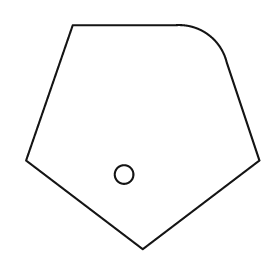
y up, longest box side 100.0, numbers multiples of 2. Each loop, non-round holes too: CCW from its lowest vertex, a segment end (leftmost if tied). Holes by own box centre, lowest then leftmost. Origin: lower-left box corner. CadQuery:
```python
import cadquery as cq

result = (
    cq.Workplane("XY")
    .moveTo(50.0, 0.0)
    .lineTo(100.0, 38.0)
    .lineTo(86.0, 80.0)
    .threePointArc((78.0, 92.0), (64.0, 96.0))
    .lineTo(20.0, 96.0)
    .lineTo(0.0, 38.0)
    .close()
    .moveTo(42.0, 32.0)
    .circle(4.0)
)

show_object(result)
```